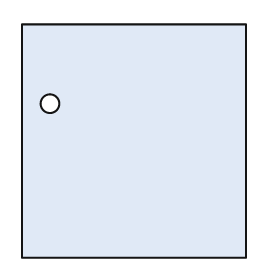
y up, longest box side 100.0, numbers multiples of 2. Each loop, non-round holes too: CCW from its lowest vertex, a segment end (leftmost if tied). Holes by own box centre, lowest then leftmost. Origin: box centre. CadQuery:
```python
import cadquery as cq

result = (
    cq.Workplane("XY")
    .moveTo(-48.0, -50.0)
    .lineTo(48.0, -50.0)
    .lineTo(48.0, 50.0)
    .lineTo(-48.0, 50.0)
    .close()
    .moveTo(-36.0, 16.0)
    .circle(4.0)
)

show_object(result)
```